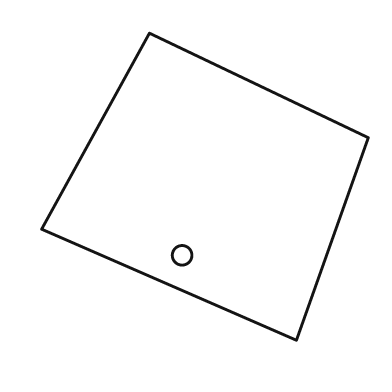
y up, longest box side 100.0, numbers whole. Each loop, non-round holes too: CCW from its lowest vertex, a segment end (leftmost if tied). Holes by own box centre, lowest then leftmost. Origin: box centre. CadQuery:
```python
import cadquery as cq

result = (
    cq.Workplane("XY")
    .moveTo(28.0, -47.0)
    .lineTo(50.0, 15.0)
    .lineTo(-17.0, 47.0)
    .lineTo(-50.0, -13.0)
    .close()
    .moveTo(-7.0, -21.0)
    .circle(3.0)
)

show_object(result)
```